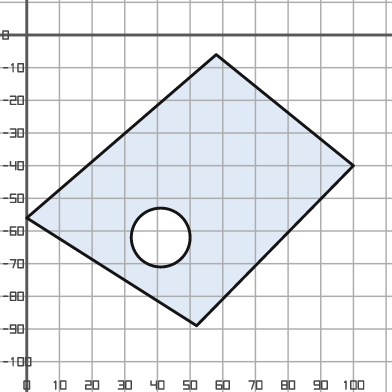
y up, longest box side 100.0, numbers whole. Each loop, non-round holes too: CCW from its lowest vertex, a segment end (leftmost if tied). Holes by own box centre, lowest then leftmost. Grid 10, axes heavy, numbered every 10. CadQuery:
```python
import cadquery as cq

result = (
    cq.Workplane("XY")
    .moveTo(52.0, -89.0)
    .lineTo(100.0, -40.0)
    .lineTo(58.0, -6.0)
    .lineTo(0.0, -56.0)
    .close()
    .moveTo(41.0, -62.0)
    .circle(9.0)
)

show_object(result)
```